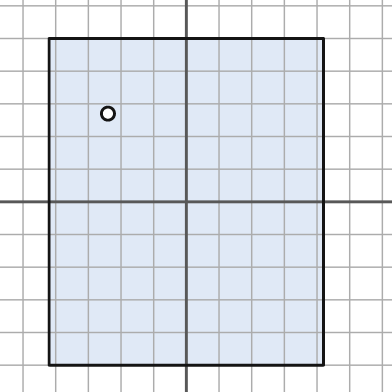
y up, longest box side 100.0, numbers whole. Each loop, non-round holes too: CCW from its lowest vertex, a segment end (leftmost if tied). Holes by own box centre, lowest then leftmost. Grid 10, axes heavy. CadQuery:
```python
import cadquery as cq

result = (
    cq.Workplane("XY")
    .moveTo(-42.0, -50.0)
    .lineTo(42.0, -50.0)
    .lineTo(42.0, 50.0)
    .lineTo(-42.0, 50.0)
    .close()
    .moveTo(-24.0, 27.0)
    .circle(2.0)
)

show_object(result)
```